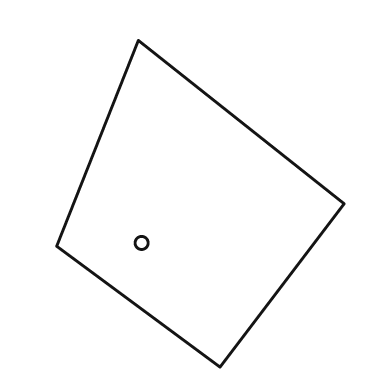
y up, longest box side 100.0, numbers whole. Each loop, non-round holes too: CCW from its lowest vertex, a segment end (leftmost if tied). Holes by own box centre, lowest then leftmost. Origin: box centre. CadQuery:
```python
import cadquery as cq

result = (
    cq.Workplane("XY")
    .moveTo(6.0, -50.0)
    .lineTo(44.0, 0.0)
    .lineTo(-19.0, 50.0)
    .lineTo(-44.0, -13.0)
    .close()
    .moveTo(-18.0, -12.0)
    .circle(2.0)
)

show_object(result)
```